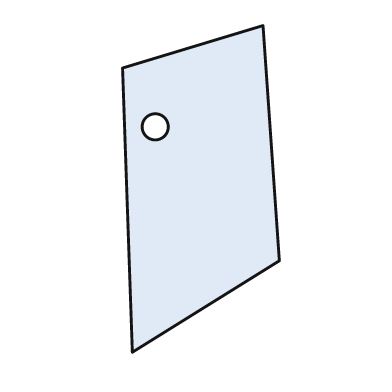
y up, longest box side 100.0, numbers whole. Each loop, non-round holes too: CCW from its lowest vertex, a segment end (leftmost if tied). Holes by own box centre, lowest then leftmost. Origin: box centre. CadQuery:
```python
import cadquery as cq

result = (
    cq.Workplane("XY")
    .moveTo(-21.0, -50.0)
    .lineTo(24.0, -22.0)
    .lineTo(19.0, 50.0)
    .lineTo(-24.0, 37.0)
    .close()
    .moveTo(-14.0, 19.0)
    .circle(4.0)
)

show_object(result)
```